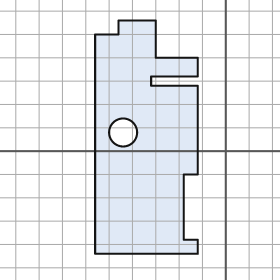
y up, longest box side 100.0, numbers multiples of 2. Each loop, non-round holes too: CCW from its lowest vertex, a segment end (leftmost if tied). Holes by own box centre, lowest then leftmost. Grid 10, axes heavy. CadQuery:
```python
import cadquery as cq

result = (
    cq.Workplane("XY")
    .moveTo(-56.0, -44.0)
    .lineTo(-12.0, -44.0)
    .lineTo(-12.0, -38.0)
    .lineTo(-18.0, -38.0)
    .lineTo(-18.0, -10.0)
    .lineTo(-12.0, -10.0)
    .lineTo(-12.0, 28.0)
    .lineTo(-32.0, 28.0)
    .lineTo(-32.0, 32.0)
    .lineTo(-12.0, 32.0)
    .lineTo(-12.0, 40.0)
    .lineTo(-30.0, 40.0)
    .lineTo(-30.0, 56.0)
    .lineTo(-46.0, 56.0)
    .lineTo(-46.0, 50.0)
    .lineTo(-56.0, 50.0)
    .close()
    .moveTo(-44.0, 8.0)
    .circle(6.0)
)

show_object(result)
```